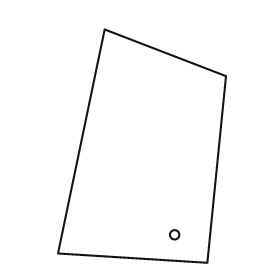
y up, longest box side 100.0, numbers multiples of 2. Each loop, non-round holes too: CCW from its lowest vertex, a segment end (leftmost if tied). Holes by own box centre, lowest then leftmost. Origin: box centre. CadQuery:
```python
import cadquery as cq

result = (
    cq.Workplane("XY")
    .moveTo(28.0, -50.0)
    .lineTo(36.0, 30.0)
    .lineTo(-16.0, 50.0)
    .lineTo(-36.0, -46.0)
    .close()
    .moveTo(14.0, -38.0)
    .circle(2.0)
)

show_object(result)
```